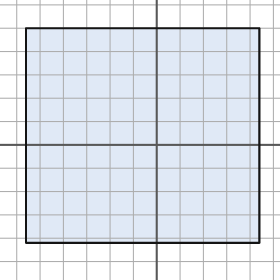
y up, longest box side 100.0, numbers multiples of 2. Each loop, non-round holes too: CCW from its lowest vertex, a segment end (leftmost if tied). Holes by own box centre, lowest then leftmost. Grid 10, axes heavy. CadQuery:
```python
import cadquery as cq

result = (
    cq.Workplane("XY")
    .moveTo(-56.0, -42.0)
    .lineTo(44.0, -42.0)
    .lineTo(44.0, 50.0)
    .lineTo(-56.0, 50.0)
    .close()
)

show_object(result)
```